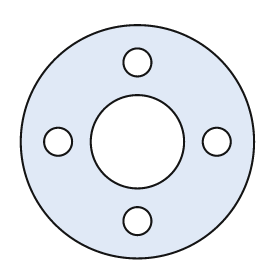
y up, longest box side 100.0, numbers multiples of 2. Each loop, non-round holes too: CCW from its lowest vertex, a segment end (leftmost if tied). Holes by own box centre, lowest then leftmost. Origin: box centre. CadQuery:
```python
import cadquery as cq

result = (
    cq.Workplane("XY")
    .moveTo(0.0, 0.0)
    .circle(50.0)
    .moveTo(0.0, -34.0)
    .circle(6.0)
    .moveTo(-34.0, 0.0)
    .circle(6.0)
    .moveTo(0.0, 0.0)
    .circle(20.0)
    .moveTo(34.0, 0.0)
    .circle(6.0)
    .moveTo(0.0, 34.0)
    .circle(6.0)
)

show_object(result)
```